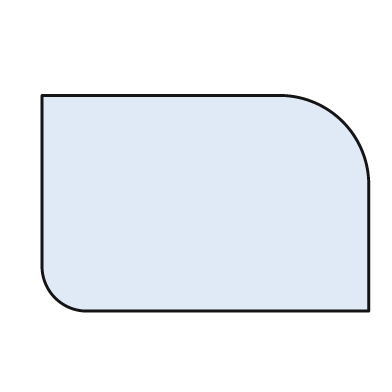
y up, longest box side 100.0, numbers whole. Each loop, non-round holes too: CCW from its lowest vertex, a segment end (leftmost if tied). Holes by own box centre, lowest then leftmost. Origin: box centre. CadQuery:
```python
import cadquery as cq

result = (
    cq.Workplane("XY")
    .moveTo(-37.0, -33.0)
    .lineTo(50.0, -33.0)
    .lineTo(50.0, 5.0)
    .threePointArc((42.0, 25.0), (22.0, 33.0))
    .lineTo(-50.0, 33.0)
    .lineTo(-50.0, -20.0)
    .threePointArc((-46.0, -29.0), (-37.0, -33.0))
    .close()
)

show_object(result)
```